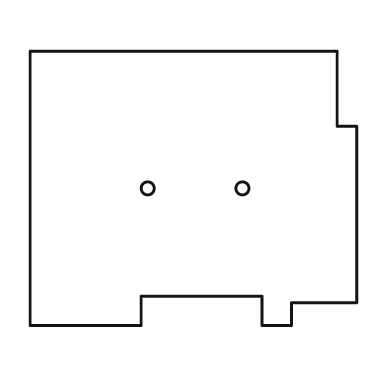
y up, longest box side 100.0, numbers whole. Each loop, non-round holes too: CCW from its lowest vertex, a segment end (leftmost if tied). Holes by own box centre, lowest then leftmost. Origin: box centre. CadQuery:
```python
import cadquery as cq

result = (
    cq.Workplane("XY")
    .moveTo(-50.0, -42.0)
    .lineTo(-16.0, -42.0)
    .lineTo(-16.0, -33.0)
    .lineTo(21.0, -33.0)
    .lineTo(21.0, -42.0)
    .lineTo(30.0, -42.0)
    .lineTo(30.0, -35.0)
    .lineTo(50.0, -35.0)
    .lineTo(50.0, 19.0)
    .lineTo(44.0, 19.0)
    .lineTo(44.0, 42.0)
    .lineTo(-50.0, 42.0)
    .close()
    .moveTo(-14.0, 0.0)
    .circle(2.0)
    .moveTo(15.0, 0.0)
    .circle(2.0)
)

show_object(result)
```